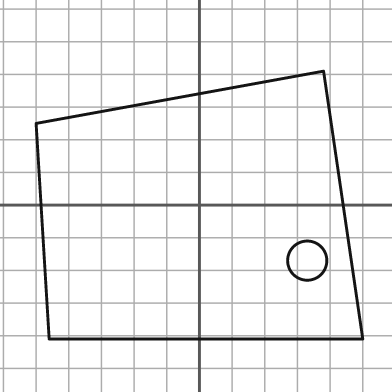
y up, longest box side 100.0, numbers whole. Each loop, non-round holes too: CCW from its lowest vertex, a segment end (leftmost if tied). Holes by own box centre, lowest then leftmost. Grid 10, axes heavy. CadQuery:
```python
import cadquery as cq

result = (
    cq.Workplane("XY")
    .moveTo(-46.0, -41.0)
    .lineTo(50.0, -41.0)
    .lineTo(38.0, 41.0)
    .lineTo(-50.0, 25.0)
    .close()
    .moveTo(33.0, -17.0)
    .circle(6.0)
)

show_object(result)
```